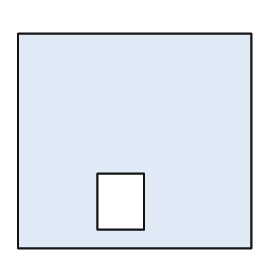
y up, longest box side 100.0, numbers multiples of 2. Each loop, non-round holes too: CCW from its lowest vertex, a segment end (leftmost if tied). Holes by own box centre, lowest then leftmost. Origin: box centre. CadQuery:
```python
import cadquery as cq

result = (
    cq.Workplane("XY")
    .moveTo(-50.0, -46.0)
    .lineTo(50.0, -46.0)
    .lineTo(50.0, 46.0)
    .lineTo(-50.0, 46.0)
    .close()
    .moveTo(-16.0, -38.0)
    .lineTo(4.0, -38.0)
    .lineTo(4.0, -14.0)
    .lineTo(-16.0, -14.0)
    .close()
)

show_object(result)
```